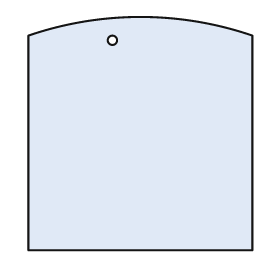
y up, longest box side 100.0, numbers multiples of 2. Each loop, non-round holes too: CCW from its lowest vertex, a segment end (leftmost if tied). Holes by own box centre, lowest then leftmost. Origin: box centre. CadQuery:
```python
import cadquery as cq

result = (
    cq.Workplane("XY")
    .moveTo(-48.0, -50.0)
    .lineTo(48.0, -50.0)
    .lineTo(48.0, 42.0)
    .threePointArc((0.0, 50.0), (-48.0, 42.0))
    .close()
    .moveTo(-12.0, 40.0)
    .circle(2.0)
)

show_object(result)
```